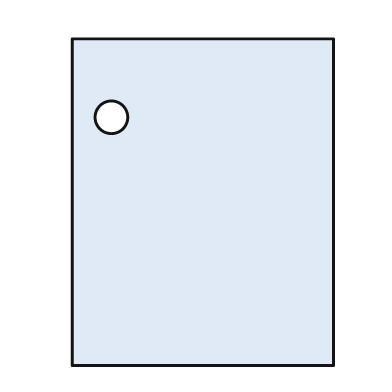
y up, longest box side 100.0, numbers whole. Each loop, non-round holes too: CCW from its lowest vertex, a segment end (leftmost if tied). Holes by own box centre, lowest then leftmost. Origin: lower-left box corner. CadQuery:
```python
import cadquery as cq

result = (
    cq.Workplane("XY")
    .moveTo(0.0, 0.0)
    .lineTo(80.0, 0.0)
    .lineTo(80.0, 100.0)
    .lineTo(0.0, 100.0)
    .close()
    .moveTo(12.0, 76.0)
    .circle(5.0)
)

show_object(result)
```